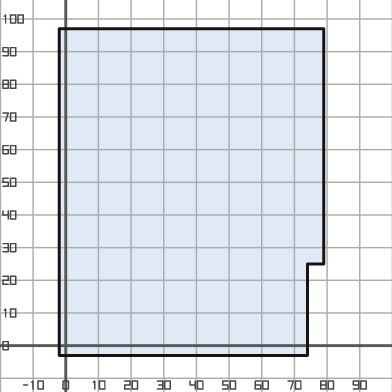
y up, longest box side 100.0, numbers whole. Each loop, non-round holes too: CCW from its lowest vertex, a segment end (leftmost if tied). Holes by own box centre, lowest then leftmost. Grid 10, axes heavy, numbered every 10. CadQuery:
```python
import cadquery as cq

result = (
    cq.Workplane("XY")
    .moveTo(-2.0, -3.0)
    .lineTo(74.0, -3.0)
    .lineTo(74.0, 25.0)
    .lineTo(79.0, 25.0)
    .lineTo(79.0, 97.0)
    .lineTo(-2.0, 97.0)
    .close()
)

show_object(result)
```